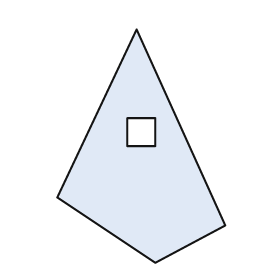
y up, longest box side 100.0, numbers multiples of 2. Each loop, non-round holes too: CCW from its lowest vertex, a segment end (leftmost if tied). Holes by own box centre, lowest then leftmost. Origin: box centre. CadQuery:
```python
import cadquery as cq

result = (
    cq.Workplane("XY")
    .moveTo(6.0, -50.0)
    .lineTo(36.0, -34.0)
    .lineTo(-2.0, 50.0)
    .lineTo(-36.0, -22.0)
    .close()
    .moveTo(-6.0, 0.0)
    .lineTo(6.0, 0.0)
    .lineTo(6.0, 12.0)
    .lineTo(-6.0, 12.0)
    .close()
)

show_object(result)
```